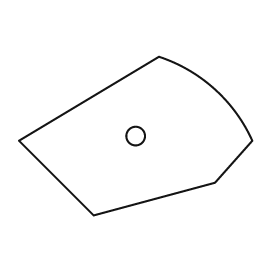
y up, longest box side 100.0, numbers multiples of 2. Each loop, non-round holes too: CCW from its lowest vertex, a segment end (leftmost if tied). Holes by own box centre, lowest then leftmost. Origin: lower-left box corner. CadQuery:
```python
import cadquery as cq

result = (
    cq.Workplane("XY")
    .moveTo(32.0, 0.0)
    .lineTo(84.0, 14.0)
    .lineTo(100.0, 32.0)
    .threePointArc((84.0, 54.0), (60.0, 68.0))
    .lineTo(0.0, 32.0)
    .close()
    .moveTo(50.0, 34.0)
    .circle(4.0)
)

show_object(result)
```